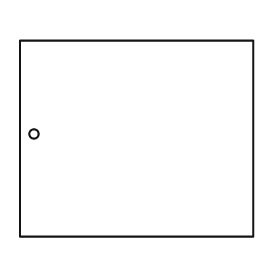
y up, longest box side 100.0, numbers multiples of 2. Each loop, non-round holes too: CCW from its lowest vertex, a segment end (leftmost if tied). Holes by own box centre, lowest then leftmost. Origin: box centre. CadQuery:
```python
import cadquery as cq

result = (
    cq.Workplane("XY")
    .moveTo(-50.0, -42.0)
    .lineTo(50.0, -42.0)
    .lineTo(50.0, 42.0)
    .lineTo(-50.0, 42.0)
    .close()
    .moveTo(-44.0, 2.0)
    .circle(2.0)
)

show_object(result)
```